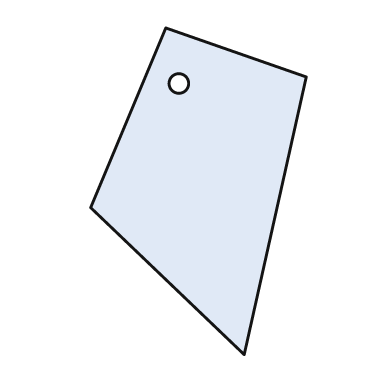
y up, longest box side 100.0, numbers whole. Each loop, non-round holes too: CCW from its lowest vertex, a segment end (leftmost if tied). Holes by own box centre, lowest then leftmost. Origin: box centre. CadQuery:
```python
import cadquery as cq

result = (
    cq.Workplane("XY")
    .moveTo(14.0, -50.0)
    .lineTo(33.0, 35.0)
    .lineTo(-10.0, 50.0)
    .lineTo(-33.0, -5.0)
    .close()
    .moveTo(-6.0, 33.0)
    .circle(3.0)
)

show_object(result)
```